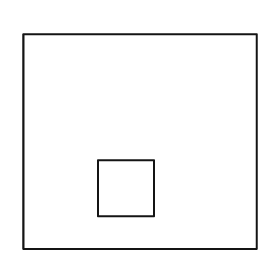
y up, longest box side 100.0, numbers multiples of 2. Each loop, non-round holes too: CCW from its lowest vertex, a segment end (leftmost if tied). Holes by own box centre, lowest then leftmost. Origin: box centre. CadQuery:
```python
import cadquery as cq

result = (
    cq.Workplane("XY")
    .moveTo(-50.0, -46.0)
    .lineTo(50.0, -46.0)
    .lineTo(50.0, 46.0)
    .lineTo(-50.0, 46.0)
    .close()
    .moveTo(-18.0, -32.0)
    .lineTo(6.0, -32.0)
    .lineTo(6.0, -8.0)
    .lineTo(-18.0, -8.0)
    .close()
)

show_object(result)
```